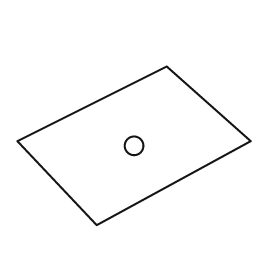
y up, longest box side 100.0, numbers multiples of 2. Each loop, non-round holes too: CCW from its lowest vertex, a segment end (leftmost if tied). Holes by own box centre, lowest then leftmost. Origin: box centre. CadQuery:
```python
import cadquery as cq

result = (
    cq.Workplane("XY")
    .moveTo(-16.0, -34.0)
    .lineTo(50.0, 2.0)
    .lineTo(14.0, 34.0)
    .lineTo(-50.0, 2.0)
    .close()
    .moveTo(0.0, 0.0)
    .circle(4.0)
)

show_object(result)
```